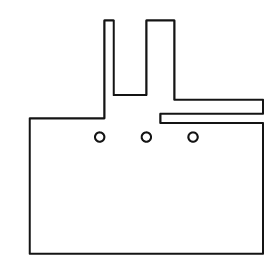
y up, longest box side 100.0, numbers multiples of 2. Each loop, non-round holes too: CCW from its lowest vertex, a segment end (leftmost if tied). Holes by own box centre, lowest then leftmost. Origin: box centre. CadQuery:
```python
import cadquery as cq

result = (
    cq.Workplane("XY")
    .moveTo(-50.0, -50.0)
    .lineTo(50.0, -50.0)
    .lineTo(50.0, 6.0)
    .lineTo(6.0, 6.0)
    .lineTo(6.0, 10.0)
    .lineTo(50.0, 10.0)
    .lineTo(50.0, 16.0)
    .lineTo(12.0, 16.0)
    .lineTo(12.0, 50.0)
    .lineTo(0.0, 50.0)
    .lineTo(0.0, 18.0)
    .lineTo(-14.0, 18.0)
    .lineTo(-14.0, 50.0)
    .lineTo(-18.0, 50.0)
    .lineTo(-18.0, 8.0)
    .lineTo(-50.0, 8.0)
    .close()
    .moveTo(-20.0, 0.0)
    .circle(2.0)
    .moveTo(0.0, 0.0)
    .circle(2.0)
    .moveTo(20.0, 0.0)
    .circle(2.0)
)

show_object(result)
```